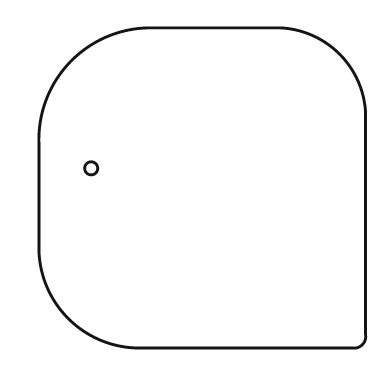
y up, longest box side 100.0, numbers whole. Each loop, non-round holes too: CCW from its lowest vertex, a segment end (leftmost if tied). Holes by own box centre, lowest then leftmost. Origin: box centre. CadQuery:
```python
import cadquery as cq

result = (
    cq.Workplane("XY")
    .moveTo(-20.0, -49.0)
    .lineTo(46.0, -49.0)
    .threePointArc((49.0, -48.0), (50.0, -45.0))
    .lineTo(50.0, 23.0)
    .threePointArc((42.0, 41.0), (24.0, 49.0))
    .lineTo(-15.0, 49.0)
    .threePointArc((-40.0, 39.0), (-50.0, 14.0))
    .lineTo(-50.0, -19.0)
    .threePointArc((-41.0, -40.0), (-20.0, -49.0))
    .close()
    .moveTo(-34.0, 6.0)
    .circle(2.0)
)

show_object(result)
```